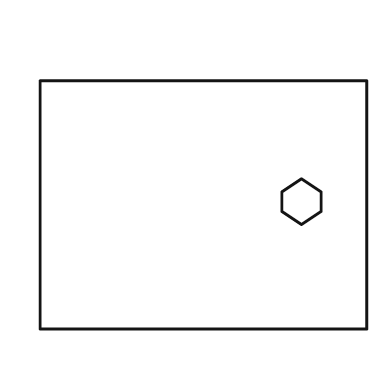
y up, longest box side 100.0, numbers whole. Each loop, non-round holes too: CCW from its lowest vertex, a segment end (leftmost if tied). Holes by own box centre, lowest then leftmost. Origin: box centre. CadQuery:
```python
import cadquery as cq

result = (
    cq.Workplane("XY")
    .moveTo(-50.0, -38.0)
    .lineTo(50.0, -38.0)
    .lineTo(50.0, 38.0)
    .lineTo(-50.0, 38.0)
    .close()
    .moveTo(30.0, -6.0)
    .lineTo(36.0, -2.0)
    .lineTo(36.0, 4.0)
    .lineTo(30.0, 8.0)
    .lineTo(24.0, 4.0)
    .lineTo(24.0, -2.0)
    .close()
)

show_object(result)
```